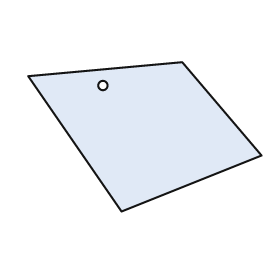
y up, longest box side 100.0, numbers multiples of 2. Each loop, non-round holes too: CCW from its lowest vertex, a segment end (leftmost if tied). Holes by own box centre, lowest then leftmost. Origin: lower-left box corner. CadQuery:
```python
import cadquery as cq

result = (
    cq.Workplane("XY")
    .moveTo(40.0, 0.0)
    .lineTo(100.0, 24.0)
    .lineTo(66.0, 64.0)
    .lineTo(0.0, 58.0)
    .close()
    .moveTo(32.0, 54.0)
    .circle(2.0)
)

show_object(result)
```